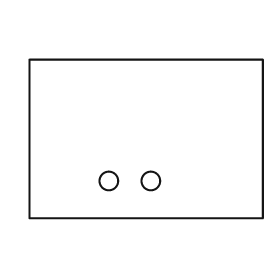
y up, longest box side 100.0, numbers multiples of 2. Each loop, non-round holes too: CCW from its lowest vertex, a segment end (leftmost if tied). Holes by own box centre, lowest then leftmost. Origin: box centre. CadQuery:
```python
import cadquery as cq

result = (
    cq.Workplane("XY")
    .moveTo(-50.0, -34.0)
    .lineTo(50.0, -34.0)
    .lineTo(50.0, 34.0)
    .lineTo(-50.0, 34.0)
    .close()
    .moveTo(-16.0, -18.0)
    .circle(4.0)
    .moveTo(2.0, -18.0)
    .circle(4.0)
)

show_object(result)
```